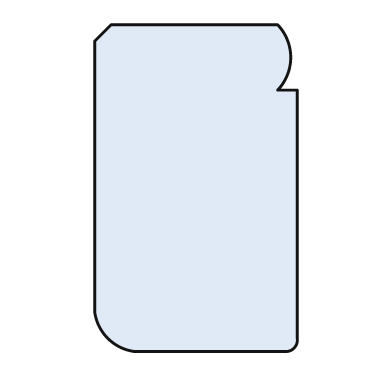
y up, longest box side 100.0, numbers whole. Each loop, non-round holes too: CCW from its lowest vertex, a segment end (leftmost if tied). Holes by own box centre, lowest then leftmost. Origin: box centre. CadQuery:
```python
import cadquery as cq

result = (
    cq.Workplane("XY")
    .moveTo(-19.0, -50.0)
    .lineTo(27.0, -50.0)
    .threePointArc((30.0, -49.0), (31.0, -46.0))
    .lineTo(31.0, 30.0)
    .lineTo(25.0, 30.0)
    .threePointArc((29.0, 40.0), (25.0, 50.0))
    .lineTo(-26.0, 50.0)
    .lineTo(-31.0, 45.0)
    .lineTo(-31.0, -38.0)
    .threePointArc((-27.0, -46.0), (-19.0, -50.0))
    .close()
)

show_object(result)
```